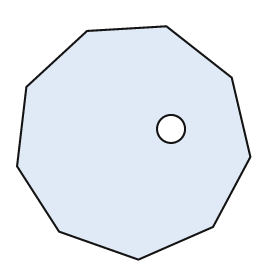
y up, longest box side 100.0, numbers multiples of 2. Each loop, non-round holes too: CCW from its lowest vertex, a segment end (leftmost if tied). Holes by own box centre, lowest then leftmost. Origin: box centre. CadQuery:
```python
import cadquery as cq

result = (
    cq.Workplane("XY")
    .moveTo(2.0, -50.0)
    .lineTo(34.0, -36.0)
    .lineTo(50.0, -6.0)
    .lineTo(42.0, 28.0)
    .lineTo(14.0, 50.0)
    .lineTo(-20.0, 48.0)
    .lineTo(-46.0, 24.0)
    .lineTo(-50.0, -10.0)
    .lineTo(-32.0, -38.0)
    .close()
    .moveTo(16.0, 6.0)
    .circle(6.0)
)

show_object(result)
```